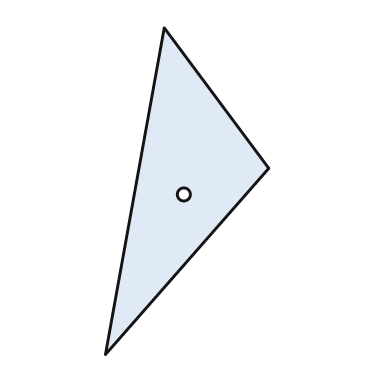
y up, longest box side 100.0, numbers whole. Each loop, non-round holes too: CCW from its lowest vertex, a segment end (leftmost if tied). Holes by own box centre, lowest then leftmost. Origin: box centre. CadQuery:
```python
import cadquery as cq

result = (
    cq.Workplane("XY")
    .moveTo(-25.0, -50.0)
    .lineTo(25.0, 7.0)
    .lineTo(-7.0, 50.0)
    .close()
    .moveTo(-1.0, -1.0)
    .circle(2.0)
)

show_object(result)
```